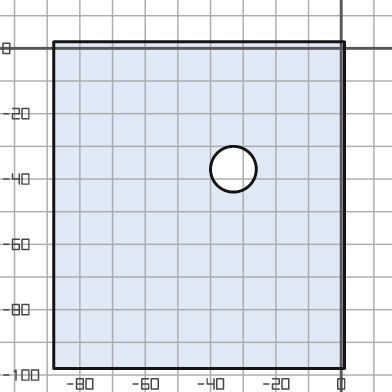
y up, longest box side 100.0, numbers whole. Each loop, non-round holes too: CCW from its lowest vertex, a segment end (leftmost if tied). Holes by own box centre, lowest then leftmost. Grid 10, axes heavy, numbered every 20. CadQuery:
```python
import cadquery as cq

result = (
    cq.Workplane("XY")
    .moveTo(-88.0, -98.0)
    .lineTo(1.0, -98.0)
    .lineTo(1.0, 2.0)
    .lineTo(-88.0, 2.0)
    .close()
    .moveTo(-33.0, -37.0)
    .circle(7.0)
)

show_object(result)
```